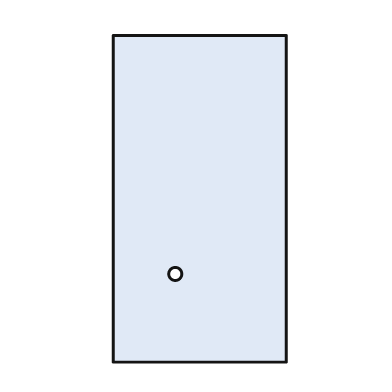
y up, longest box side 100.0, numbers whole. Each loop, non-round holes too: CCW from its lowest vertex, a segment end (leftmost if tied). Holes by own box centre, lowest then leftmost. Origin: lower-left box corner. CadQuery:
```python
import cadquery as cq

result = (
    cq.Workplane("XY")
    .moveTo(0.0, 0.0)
    .lineTo(53.0, 0.0)
    .lineTo(53.0, 100.0)
    .lineTo(0.0, 100.0)
    .close()
    .moveTo(19.0, 27.0)
    .circle(2.0)
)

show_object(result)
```